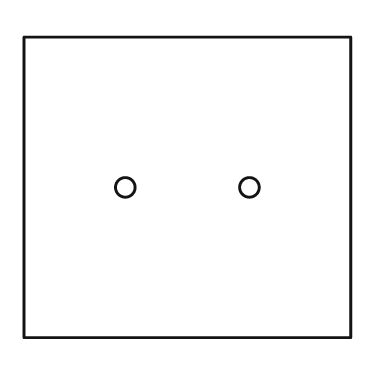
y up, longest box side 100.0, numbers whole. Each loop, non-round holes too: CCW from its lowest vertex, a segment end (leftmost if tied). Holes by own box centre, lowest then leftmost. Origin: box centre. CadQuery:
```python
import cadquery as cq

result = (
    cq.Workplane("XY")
    .moveTo(-50.0, -46.0)
    .lineTo(50.0, -46.0)
    .lineTo(50.0, 46.0)
    .lineTo(-50.0, 46.0)
    .close()
    .moveTo(-19.0, 0.0)
    .circle(3.0)
    .moveTo(19.0, 0.0)
    .circle(3.0)
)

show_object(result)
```